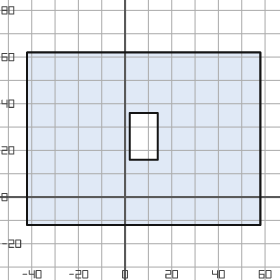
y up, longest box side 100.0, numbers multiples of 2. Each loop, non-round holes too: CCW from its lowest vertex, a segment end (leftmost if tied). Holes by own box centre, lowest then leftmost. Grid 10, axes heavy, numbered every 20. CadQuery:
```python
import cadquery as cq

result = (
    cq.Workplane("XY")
    .moveTo(-42.0, -12.0)
    .lineTo(58.0, -12.0)
    .lineTo(58.0, 62.0)
    .lineTo(-42.0, 62.0)
    .close()
    .moveTo(2.0, 16.0)
    .lineTo(14.0, 16.0)
    .lineTo(14.0, 36.0)
    .lineTo(2.0, 36.0)
    .close()
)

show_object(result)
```